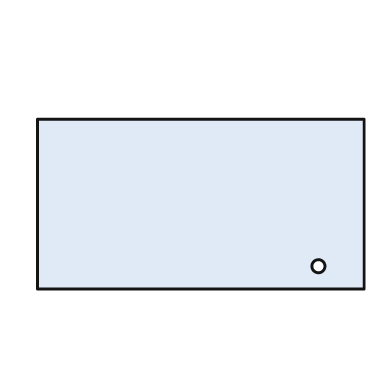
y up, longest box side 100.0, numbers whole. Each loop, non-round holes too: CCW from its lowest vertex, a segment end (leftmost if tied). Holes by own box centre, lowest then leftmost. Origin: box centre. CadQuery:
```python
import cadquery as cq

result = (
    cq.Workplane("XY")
    .moveTo(-50.0, -26.0)
    .lineTo(50.0, -26.0)
    .lineTo(50.0, 26.0)
    .lineTo(-50.0, 26.0)
    .close()
    .moveTo(36.0, -19.0)
    .circle(2.0)
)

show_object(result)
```